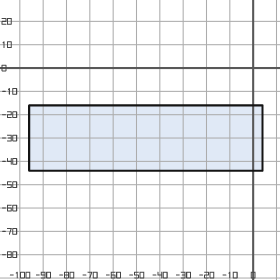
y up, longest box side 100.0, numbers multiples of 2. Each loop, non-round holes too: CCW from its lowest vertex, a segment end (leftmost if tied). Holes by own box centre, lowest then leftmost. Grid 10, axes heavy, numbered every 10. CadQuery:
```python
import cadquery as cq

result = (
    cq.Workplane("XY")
    .moveTo(-96.0, -44.0)
    .lineTo(4.0, -44.0)
    .lineTo(4.0, -16.0)
    .lineTo(-96.0, -16.0)
    .close()
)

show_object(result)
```